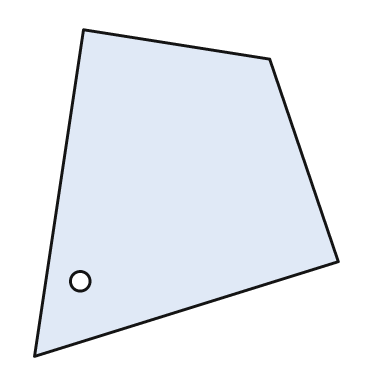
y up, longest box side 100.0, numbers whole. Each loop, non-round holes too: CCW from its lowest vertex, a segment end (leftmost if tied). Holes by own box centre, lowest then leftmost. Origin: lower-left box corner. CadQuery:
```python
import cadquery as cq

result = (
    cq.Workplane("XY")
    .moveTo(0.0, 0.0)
    .lineTo(93.0, 29.0)
    .lineTo(72.0, 91.0)
    .lineTo(15.0, 100.0)
    .close()
    .moveTo(14.0, 23.0)
    .circle(3.0)
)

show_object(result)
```